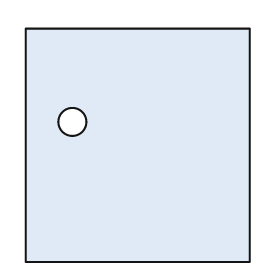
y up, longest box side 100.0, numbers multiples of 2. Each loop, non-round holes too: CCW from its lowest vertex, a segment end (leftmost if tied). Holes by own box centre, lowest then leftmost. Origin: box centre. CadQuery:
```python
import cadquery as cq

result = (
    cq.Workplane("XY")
    .moveTo(-48.0, -50.0)
    .lineTo(48.0, -50.0)
    .lineTo(48.0, 50.0)
    .lineTo(-48.0, 50.0)
    .close()
    .moveTo(-28.0, 10.0)
    .circle(6.0)
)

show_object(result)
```